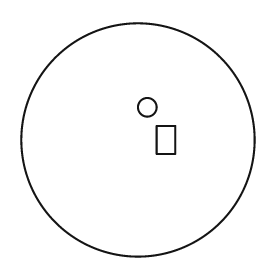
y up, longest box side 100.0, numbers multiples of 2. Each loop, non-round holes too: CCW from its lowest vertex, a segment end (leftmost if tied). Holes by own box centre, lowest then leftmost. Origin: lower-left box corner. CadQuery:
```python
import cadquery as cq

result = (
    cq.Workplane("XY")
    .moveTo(50.0, 50.0)
    .circle(50.0)
    .moveTo(58.0, 44.0)
    .lineTo(66.0, 44.0)
    .lineTo(66.0, 56.0)
    .lineTo(58.0, 56.0)
    .close()
    .moveTo(54.0, 64.0)
    .circle(4.0)
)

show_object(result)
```